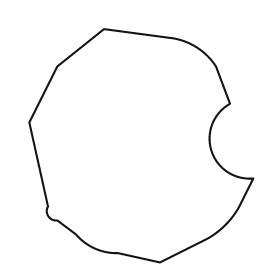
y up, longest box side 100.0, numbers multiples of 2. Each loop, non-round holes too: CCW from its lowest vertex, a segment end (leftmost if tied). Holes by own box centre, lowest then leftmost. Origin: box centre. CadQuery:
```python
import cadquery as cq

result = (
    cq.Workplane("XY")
    .moveTo(8.0, -50.0)
    .lineTo(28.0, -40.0)
    .threePointArc((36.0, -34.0), (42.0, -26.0))
    .lineTo(48.0, -14.0)
    .threePointArc((30.0, -2.0), (38.0, 18.0))
    .lineTo(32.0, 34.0)
    .threePointArc((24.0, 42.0), (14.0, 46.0))
    .lineTo(-16.0, 50.0)
    .lineTo(-36.0, 34.0)
    .lineTo(-48.0, 10.0)
    .lineTo(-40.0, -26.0)
    .threePointArc((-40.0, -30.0), (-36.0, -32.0))
    .lineTo(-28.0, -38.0)
    .threePointArc((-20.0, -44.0), (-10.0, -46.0))
    .close()
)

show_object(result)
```